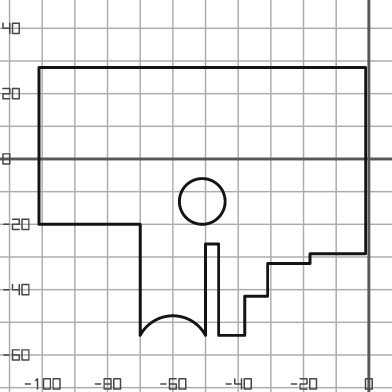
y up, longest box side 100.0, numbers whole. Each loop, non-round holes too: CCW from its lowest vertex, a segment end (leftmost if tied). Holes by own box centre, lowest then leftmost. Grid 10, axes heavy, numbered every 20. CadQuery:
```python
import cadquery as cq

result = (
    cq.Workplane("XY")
    .moveTo(-70.0, -54.0)
    .threePointArc((-60.0, -48.0), (-50.0, -54.0))
    .lineTo(-50.0, -26.0)
    .lineTo(-46.0, -26.0)
    .lineTo(-46.0, -54.0)
    .lineTo(-38.0, -54.0)
    .lineTo(-38.0, -42.0)
    .lineTo(-31.0, -42.0)
    .lineTo(-31.0, -32.0)
    .lineTo(-18.0, -32.0)
    .lineTo(-18.0, -29.0)
    .lineTo(-1.0, -29.0)
    .lineTo(-1.0, 28.0)
    .lineTo(-101.0, 28.0)
    .lineTo(-101.0, -20.0)
    .lineTo(-70.0, -20.0)
    .close()
    .moveTo(-51.0, -13.0)
    .circle(7.0)
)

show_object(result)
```